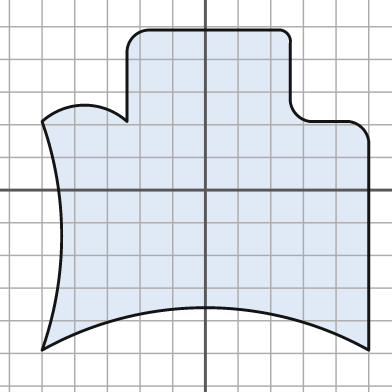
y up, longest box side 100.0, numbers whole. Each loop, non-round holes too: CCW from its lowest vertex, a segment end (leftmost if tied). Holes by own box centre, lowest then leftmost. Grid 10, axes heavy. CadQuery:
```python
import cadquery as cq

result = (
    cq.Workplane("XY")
    .moveTo(-50.0, -49.0)
    .threePointArc((0.0, -36.0), (50.0, -49.0))
    .lineTo(50.0, 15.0)
    .threePointArc((48.0, 19.0), (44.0, 21.0))
    .lineTo(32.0, 21.0)
    .threePointArc((28.0, 23.0), (26.0, 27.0))
    .lineTo(26.0, 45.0)
    .threePointArc((25.0, 48.0), (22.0, 49.0))
    .lineTo(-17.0, 49.0)
    .threePointArc((-22.0, 47.0), (-24.0, 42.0))
    .lineTo(-24.0, 21.0)
    .threePointArc((-37.0, 26.0), (-50.0, 21.0))
    .threePointArc((-44.0, -14.0), (-50.0, -49.0))
    .close()
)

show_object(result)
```